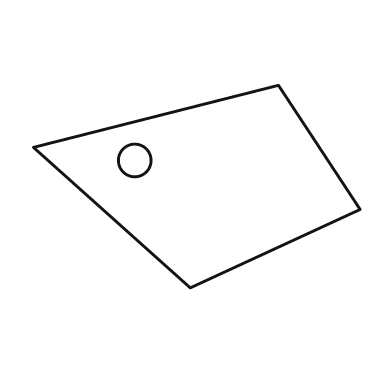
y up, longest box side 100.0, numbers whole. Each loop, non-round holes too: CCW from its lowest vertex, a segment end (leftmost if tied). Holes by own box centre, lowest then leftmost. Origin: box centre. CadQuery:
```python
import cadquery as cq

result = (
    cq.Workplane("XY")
    .moveTo(-2.0, -31.0)
    .lineTo(50.0, -7.0)
    .lineTo(25.0, 31.0)
    .lineTo(-50.0, 12.0)
    .close()
    .moveTo(-19.0, 8.0)
    .circle(5.0)
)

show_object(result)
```